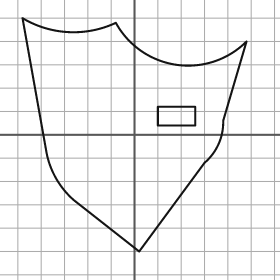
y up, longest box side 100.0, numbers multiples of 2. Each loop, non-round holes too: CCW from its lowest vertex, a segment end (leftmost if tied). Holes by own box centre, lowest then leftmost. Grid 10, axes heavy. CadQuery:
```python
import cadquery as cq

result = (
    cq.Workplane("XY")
    .moveTo(2.0, -50.0)
    .lineTo(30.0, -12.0)
    .threePointArc((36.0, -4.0), (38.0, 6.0))
    .lineTo(48.0, 40.0)
    .threePointArc((18.0, 30.0), (-8.0, 48.0))
    .threePointArc((-28.0, 44.0), (-48.0, 50.0))
    .lineTo(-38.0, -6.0)
    .threePointArc((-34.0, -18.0), (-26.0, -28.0))
    .close()
    .moveTo(10.0, 4.0)
    .lineTo(26.0, 4.0)
    .lineTo(26.0, 12.0)
    .lineTo(10.0, 12.0)
    .close()
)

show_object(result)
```